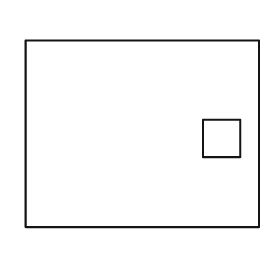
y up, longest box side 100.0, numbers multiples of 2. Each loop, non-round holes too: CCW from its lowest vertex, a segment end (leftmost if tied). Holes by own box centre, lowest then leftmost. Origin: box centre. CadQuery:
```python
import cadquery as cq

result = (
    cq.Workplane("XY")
    .moveTo(-50.0, -40.0)
    .lineTo(50.0, -40.0)
    .lineTo(50.0, 40.0)
    .lineTo(-50.0, 40.0)
    .close()
    .moveTo(26.0, -10.0)
    .lineTo(42.0, -10.0)
    .lineTo(42.0, 6.0)
    .lineTo(26.0, 6.0)
    .close()
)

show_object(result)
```